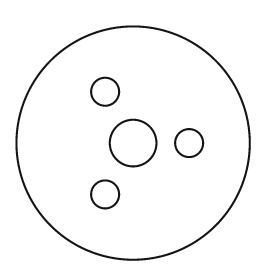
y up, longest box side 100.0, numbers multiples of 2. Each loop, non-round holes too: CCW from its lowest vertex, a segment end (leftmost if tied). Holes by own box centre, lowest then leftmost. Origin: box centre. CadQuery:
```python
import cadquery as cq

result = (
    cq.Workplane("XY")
    .moveTo(0.0, 0.0)
    .circle(50.0)
    .moveTo(-12.0, -22.0)
    .circle(6.0)
    .moveTo(0.0, 0.0)
    .circle(10.0)
    .moveTo(24.0, 0.0)
    .circle(6.0)
    .moveTo(-12.0, 22.0)
    .circle(6.0)
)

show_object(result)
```